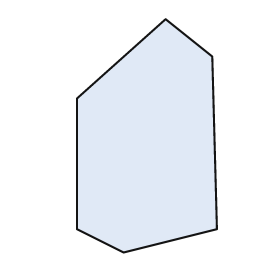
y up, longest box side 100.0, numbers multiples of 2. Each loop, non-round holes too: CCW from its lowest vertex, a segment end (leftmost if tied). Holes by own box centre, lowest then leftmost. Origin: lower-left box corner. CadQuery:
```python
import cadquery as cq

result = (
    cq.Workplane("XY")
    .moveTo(20.0, 0.0)
    .lineTo(60.0, 10.0)
    .lineTo(58.0, 84.0)
    .lineTo(38.0, 100.0)
    .lineTo(0.0, 66.0)
    .lineTo(0.0, 10.0)
    .close()
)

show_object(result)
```